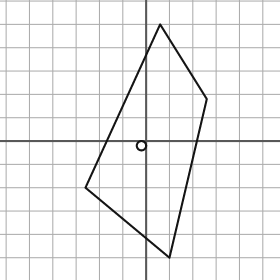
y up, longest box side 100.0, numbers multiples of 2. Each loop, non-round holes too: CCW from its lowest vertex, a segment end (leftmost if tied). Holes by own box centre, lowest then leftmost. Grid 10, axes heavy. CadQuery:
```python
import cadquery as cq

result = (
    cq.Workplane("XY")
    .moveTo(10.0, -50.0)
    .lineTo(26.0, 18.0)
    .lineTo(6.0, 50.0)
    .lineTo(-26.0, -20.0)
    .close()
    .moveTo(-2.0, -2.0)
    .circle(2.0)
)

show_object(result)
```